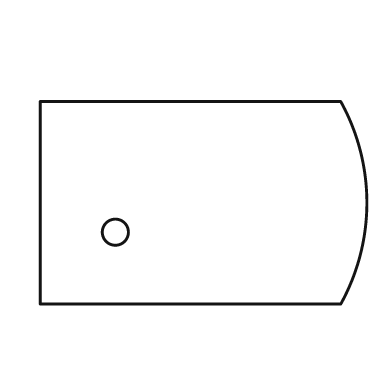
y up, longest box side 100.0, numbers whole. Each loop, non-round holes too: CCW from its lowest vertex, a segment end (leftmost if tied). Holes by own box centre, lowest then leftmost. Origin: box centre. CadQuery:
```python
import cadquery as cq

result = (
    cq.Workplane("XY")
    .moveTo(-50.0, -31.0)
    .lineTo(42.0, -31.0)
    .threePointArc((50.0, 0.0), (42.0, 31.0))
    .lineTo(-50.0, 31.0)
    .close()
    .moveTo(-27.0, -9.0)
    .circle(4.0)
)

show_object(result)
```